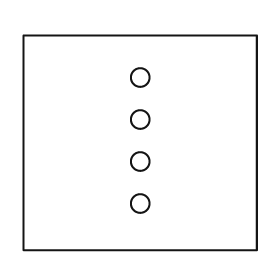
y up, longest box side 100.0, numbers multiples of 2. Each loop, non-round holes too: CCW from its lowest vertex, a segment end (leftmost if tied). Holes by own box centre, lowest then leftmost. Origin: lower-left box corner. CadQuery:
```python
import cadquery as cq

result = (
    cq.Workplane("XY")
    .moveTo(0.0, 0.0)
    .lineTo(100.0, 0.0)
    .lineTo(100.0, 92.0)
    .lineTo(0.0, 92.0)
    .close()
    .moveTo(50.0, 20.0)
    .circle(4.0)
    .moveTo(50.0, 38.0)
    .circle(4.0)
    .moveTo(50.0, 56.0)
    .circle(4.0)
    .moveTo(50.0, 74.0)
    .circle(4.0)
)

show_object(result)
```